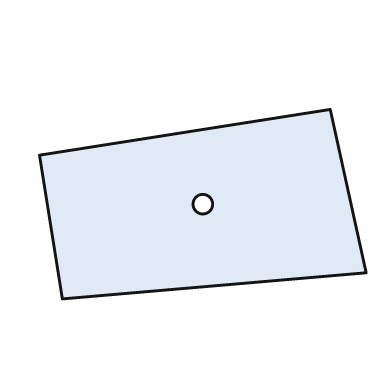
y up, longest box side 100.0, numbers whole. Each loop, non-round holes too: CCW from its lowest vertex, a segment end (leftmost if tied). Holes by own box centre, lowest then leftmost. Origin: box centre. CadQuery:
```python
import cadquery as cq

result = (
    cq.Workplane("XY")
    .moveTo(-43.0, -29.0)
    .lineTo(50.0, -21.0)
    .lineTo(39.0, 29.0)
    .lineTo(-50.0, 15.0)
    .close()
    .moveTo(0.0, 0.0)
    .circle(3.0)
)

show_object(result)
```